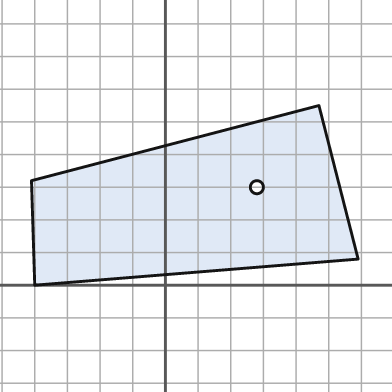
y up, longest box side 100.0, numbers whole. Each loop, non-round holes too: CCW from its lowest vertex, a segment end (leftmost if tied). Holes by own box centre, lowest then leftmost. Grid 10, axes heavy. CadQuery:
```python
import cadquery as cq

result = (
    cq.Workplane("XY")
    .moveTo(-40.0, 0.0)
    .lineTo(59.0, 8.0)
    .lineTo(47.0, 55.0)
    .lineTo(-41.0, 32.0)
    .close()
    .moveTo(28.0, 30.0)
    .circle(2.0)
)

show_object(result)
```